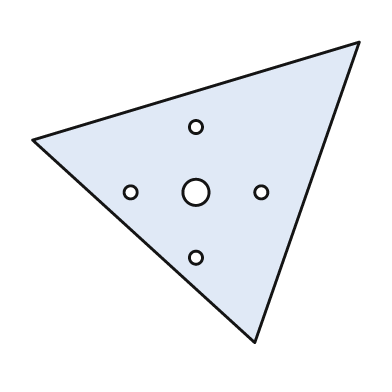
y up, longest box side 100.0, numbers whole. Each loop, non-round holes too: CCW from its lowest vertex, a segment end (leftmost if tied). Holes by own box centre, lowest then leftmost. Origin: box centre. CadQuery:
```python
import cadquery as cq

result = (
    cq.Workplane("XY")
    .moveTo(18.0, -46.0)
    .lineTo(50.0, 46.0)
    .lineTo(-50.0, 16.0)
    .close()
    .moveTo(0.0, -20.0)
    .circle(2.0)
    .moveTo(-20.0, 0.0)
    .circle(2.0)
    .moveTo(0.0, 0.0)
    .circle(4.0)
    .moveTo(20.0, 0.0)
    .circle(2.0)
    .moveTo(0.0, 20.0)
    .circle(2.0)
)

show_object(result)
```